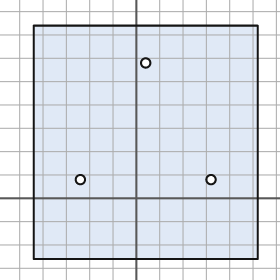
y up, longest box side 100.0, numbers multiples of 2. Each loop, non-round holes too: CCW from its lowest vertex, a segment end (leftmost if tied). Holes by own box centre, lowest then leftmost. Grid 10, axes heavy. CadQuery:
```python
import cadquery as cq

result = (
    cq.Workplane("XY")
    .moveTo(-44.0, -26.0)
    .lineTo(52.0, -26.0)
    .lineTo(52.0, 74.0)
    .lineTo(-44.0, 74.0)
    .close()
    .moveTo(-24.0, 8.0)
    .circle(2.0)
    .moveTo(32.0, 8.0)
    .circle(2.0)
    .moveTo(4.0, 58.0)
    .circle(2.0)
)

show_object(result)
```